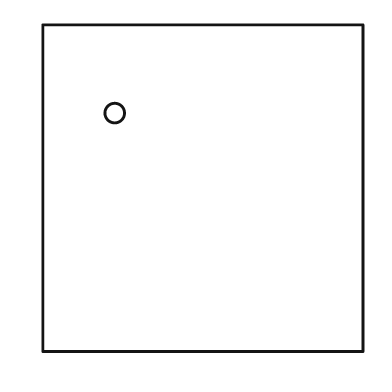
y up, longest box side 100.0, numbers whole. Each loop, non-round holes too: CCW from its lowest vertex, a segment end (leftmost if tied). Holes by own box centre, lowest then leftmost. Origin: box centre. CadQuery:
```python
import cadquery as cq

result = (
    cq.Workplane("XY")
    .moveTo(-49.0, -50.0)
    .lineTo(49.0, -50.0)
    .lineTo(49.0, 50.0)
    .lineTo(-49.0, 50.0)
    .close()
    .moveTo(-27.0, 23.0)
    .circle(3.0)
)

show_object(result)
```